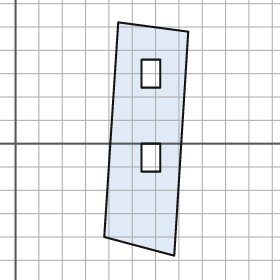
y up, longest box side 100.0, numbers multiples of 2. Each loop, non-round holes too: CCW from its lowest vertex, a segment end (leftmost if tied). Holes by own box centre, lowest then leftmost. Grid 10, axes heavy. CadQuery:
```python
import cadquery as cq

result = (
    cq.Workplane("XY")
    .moveTo(68.0, -48.0)
    .lineTo(74.0, 48.0)
    .lineTo(44.0, 52.0)
    .lineTo(38.0, -40.0)
    .close()
    .moveTo(54.0, -12.0)
    .lineTo(62.0, -12.0)
    .lineTo(62.0, 0.0)
    .lineTo(54.0, 0.0)
    .close()
    .moveTo(54.0, 24.0)
    .lineTo(62.0, 24.0)
    .lineTo(62.0, 36.0)
    .lineTo(54.0, 36.0)
    .close()
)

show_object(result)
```